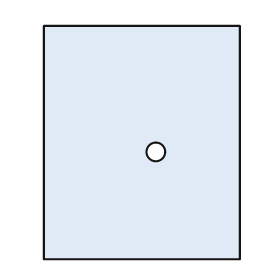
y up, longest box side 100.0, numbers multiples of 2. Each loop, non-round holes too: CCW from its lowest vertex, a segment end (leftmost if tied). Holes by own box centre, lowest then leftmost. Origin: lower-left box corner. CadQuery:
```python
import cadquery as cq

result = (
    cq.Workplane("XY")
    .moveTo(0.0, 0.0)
    .lineTo(84.0, 0.0)
    .lineTo(84.0, 100.0)
    .lineTo(0.0, 100.0)
    .close()
    .moveTo(48.0, 46.0)
    .circle(4.0)
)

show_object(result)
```